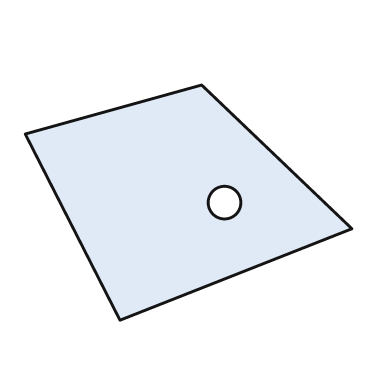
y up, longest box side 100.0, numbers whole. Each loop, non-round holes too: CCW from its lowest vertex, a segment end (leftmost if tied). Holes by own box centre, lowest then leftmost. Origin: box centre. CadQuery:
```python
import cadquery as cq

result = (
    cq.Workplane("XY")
    .moveTo(-21.0, -36.0)
    .lineTo(50.0, -8.0)
    .lineTo(4.0, 36.0)
    .lineTo(-50.0, 21.0)
    .close()
    .moveTo(11.0, 0.0)
    .circle(5.0)
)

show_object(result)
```